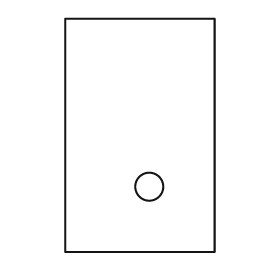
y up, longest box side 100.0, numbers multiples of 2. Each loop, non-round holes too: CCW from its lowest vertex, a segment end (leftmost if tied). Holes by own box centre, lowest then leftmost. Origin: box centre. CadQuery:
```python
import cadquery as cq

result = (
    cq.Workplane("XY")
    .moveTo(-32.0, -50.0)
    .lineTo(32.0, -50.0)
    .lineTo(32.0, 50.0)
    .lineTo(-32.0, 50.0)
    .close()
    .moveTo(4.0, -22.0)
    .circle(6.0)
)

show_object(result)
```